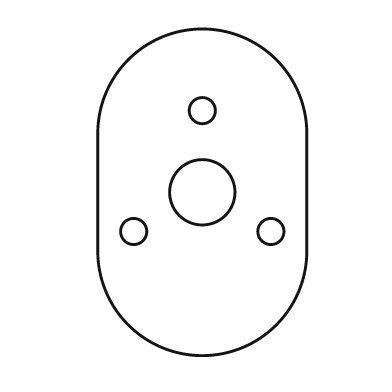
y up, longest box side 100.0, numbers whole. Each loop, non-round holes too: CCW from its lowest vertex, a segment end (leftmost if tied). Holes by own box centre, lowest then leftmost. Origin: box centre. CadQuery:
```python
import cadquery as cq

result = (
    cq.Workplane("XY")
    .moveTo(-32.0, -18.0)
    .threePointArc((0.0, -50.0), (32.0, -18.0))
    .lineTo(32.0, 18.0)
    .threePointArc((0.0, 50.0), (-32.0, 18.0))
    .close()
    .moveTo(-21.0, -12.0)
    .circle(4.0)
    .moveTo(21.0, -12.0)
    .circle(4.0)
    .moveTo(0.0, 0.0)
    .circle(10.0)
    .moveTo(0.0, 25.0)
    .circle(4.0)
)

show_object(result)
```